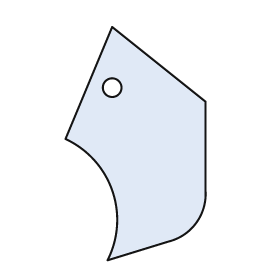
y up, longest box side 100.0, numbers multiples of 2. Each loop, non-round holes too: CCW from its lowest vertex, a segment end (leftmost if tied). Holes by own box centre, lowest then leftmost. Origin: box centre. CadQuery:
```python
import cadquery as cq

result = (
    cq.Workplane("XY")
    .moveTo(-12.0, -50.0)
    .lineTo(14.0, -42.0)
    .threePointArc((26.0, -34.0), (30.0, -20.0))
    .lineTo(30.0, 18.0)
    .lineTo(-10.0, 50.0)
    .lineTo(-30.0, 2.0)
    .threePointArc((-10.0, -20.0), (-12.0, -50.0))
    .close()
    .moveTo(-10.0, 24.0)
    .circle(4.0)
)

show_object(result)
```